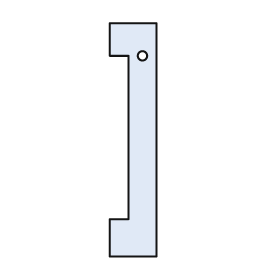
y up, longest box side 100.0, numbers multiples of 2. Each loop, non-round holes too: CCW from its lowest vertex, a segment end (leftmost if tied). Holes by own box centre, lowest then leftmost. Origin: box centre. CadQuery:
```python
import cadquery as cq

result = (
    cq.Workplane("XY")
    .moveTo(-10.0, -50.0)
    .lineTo(10.0, -50.0)
    .lineTo(10.0, 50.0)
    .lineTo(-10.0, 50.0)
    .lineTo(-10.0, 36.0)
    .lineTo(-2.0, 36.0)
    .lineTo(-2.0, -34.0)
    .lineTo(-10.0, -34.0)
    .close()
    .moveTo(4.0, 36.0)
    .circle(2.0)
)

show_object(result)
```